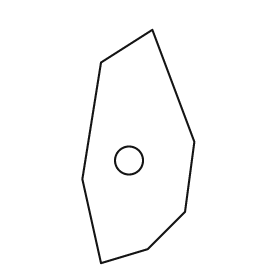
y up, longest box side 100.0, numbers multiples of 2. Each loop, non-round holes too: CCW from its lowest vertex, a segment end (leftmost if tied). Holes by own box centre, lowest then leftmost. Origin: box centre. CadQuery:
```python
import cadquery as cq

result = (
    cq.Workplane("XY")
    .moveTo(-16.0, -50.0)
    .lineTo(4.0, -44.0)
    .lineTo(20.0, -28.0)
    .lineTo(24.0, 2.0)
    .lineTo(6.0, 50.0)
    .lineTo(-16.0, 36.0)
    .lineTo(-24.0, -14.0)
    .close()
    .moveTo(-4.0, -6.0)
    .circle(6.0)
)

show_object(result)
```